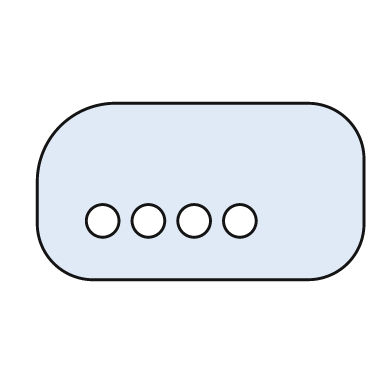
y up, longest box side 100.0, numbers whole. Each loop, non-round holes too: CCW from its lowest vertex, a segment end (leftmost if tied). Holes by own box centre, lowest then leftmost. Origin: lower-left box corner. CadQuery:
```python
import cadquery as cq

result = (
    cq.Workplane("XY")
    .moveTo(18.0, 0.0)
    .lineTo(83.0, 0.0)
    .threePointArc((95.0, 5.0), (100.0, 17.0))
    .lineTo(100.0, 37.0)
    .threePointArc((95.0, 49.0), (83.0, 54.0))
    .lineTo(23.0, 54.0)
    .threePointArc((7.0, 47.0), (0.0, 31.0))
    .lineTo(0.0, 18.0)
    .threePointArc((5.0, 5.0), (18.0, 0.0))
    .close()
    .moveTo(20.0, 18.0)
    .circle(5.0)
    .moveTo(34.0, 18.0)
    .circle(5.0)
    .moveTo(48.0, 18.0)
    .circle(5.0)
    .moveTo(62.0, 18.0)
    .circle(5.0)
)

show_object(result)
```